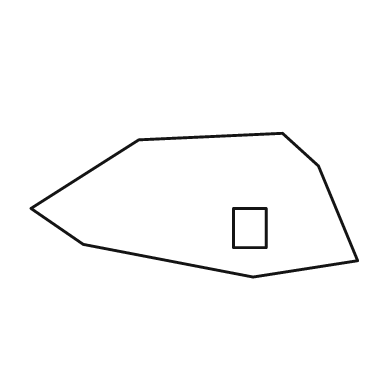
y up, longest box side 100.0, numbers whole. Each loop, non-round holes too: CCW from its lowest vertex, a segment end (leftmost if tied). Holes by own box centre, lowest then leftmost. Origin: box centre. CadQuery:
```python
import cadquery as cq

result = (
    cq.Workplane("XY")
    .moveTo(18.0, -22.0)
    .lineTo(50.0, -17.0)
    .lineTo(38.0, 12.0)
    .lineTo(27.0, 22.0)
    .lineTo(-17.0, 20.0)
    .lineTo(-50.0, -1.0)
    .lineTo(-34.0, -12.0)
    .close()
    .moveTo(12.0, -13.0)
    .lineTo(22.0, -13.0)
    .lineTo(22.0, -1.0)
    .lineTo(12.0, -1.0)
    .close()
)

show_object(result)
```